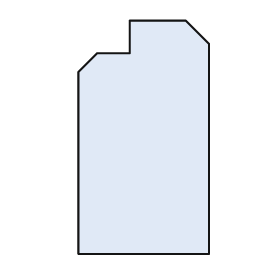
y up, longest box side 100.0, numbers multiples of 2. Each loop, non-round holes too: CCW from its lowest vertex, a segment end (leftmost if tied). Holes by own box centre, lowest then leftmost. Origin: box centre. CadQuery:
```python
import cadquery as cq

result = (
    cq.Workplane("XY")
    .moveTo(-28.0, -50.0)
    .lineTo(28.0, -50.0)
    .lineTo(28.0, 40.0)
    .lineTo(18.0, 50.0)
    .lineTo(-6.0, 50.0)
    .lineTo(-6.0, 36.0)
    .lineTo(-20.0, 36.0)
    .lineTo(-28.0, 28.0)
    .close()
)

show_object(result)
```